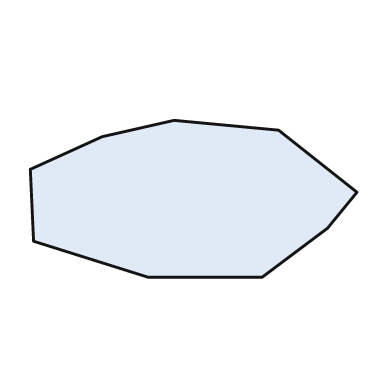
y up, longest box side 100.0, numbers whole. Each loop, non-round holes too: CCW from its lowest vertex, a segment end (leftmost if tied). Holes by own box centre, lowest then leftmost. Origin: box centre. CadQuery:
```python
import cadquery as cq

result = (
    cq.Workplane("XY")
    .moveTo(-14.0, -24.0)
    .lineTo(21.0, -24.0)
    .lineTo(41.0, -9.0)
    .lineTo(50.0, 2.0)
    .lineTo(26.0, 21.0)
    .lineTo(-6.0, 24.0)
    .lineTo(-28.0, 19.0)
    .lineTo(-50.0, 9.0)
    .lineTo(-49.0, -13.0)
    .close()
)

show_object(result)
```